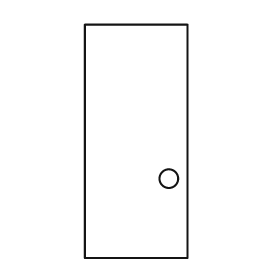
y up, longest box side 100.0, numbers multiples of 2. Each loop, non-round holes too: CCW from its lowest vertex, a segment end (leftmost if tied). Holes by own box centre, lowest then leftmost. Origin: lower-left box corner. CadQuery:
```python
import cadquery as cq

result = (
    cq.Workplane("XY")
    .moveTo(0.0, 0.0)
    .lineTo(44.0, 0.0)
    .lineTo(44.0, 100.0)
    .lineTo(0.0, 100.0)
    .close()
    .moveTo(36.0, 34.0)
    .circle(4.0)
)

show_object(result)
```